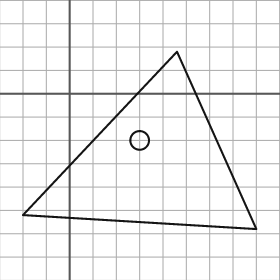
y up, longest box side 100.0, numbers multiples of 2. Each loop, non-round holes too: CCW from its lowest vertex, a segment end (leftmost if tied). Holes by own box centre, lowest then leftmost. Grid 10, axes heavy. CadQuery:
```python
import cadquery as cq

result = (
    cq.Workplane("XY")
    .moveTo(80.0, -58.0)
    .lineTo(46.0, 18.0)
    .lineTo(-20.0, -52.0)
    .close()
    .moveTo(30.0, -20.0)
    .circle(4.0)
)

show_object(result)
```